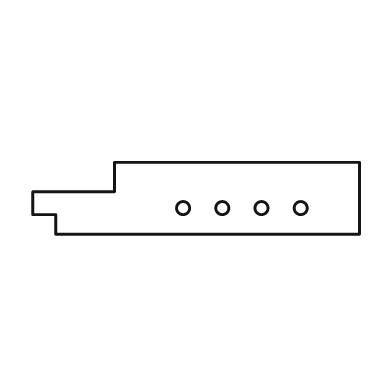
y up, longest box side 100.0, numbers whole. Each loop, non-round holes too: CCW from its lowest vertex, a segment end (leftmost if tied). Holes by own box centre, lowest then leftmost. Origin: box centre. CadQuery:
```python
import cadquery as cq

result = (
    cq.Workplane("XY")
    .moveTo(-43.0, -11.0)
    .lineTo(50.0, -11.0)
    .lineTo(50.0, 11.0)
    .lineTo(-25.0, 11.0)
    .lineTo(-25.0, 2.0)
    .lineTo(-50.0, 2.0)
    .lineTo(-50.0, -5.0)
    .lineTo(-43.0, -5.0)
    .close()
    .moveTo(-4.0, -3.0)
    .circle(2.0)
    .moveTo(8.0, -3.0)
    .circle(2.0)
    .moveTo(20.0, -3.0)
    .circle(2.0)
    .moveTo(32.0, -3.0)
    .circle(2.0)
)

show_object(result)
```